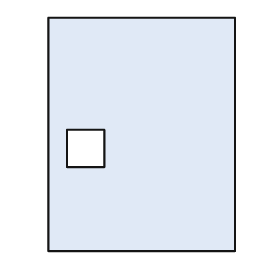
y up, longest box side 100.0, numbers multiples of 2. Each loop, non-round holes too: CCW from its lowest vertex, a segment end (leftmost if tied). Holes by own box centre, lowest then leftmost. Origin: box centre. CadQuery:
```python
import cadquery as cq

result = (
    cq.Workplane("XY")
    .moveTo(-40.0, -50.0)
    .lineTo(40.0, -50.0)
    .lineTo(40.0, 50.0)
    .lineTo(-40.0, 50.0)
    .close()
    .moveTo(-32.0, -14.0)
    .lineTo(-16.0, -14.0)
    .lineTo(-16.0, 2.0)
    .lineTo(-32.0, 2.0)
    .close()
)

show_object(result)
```